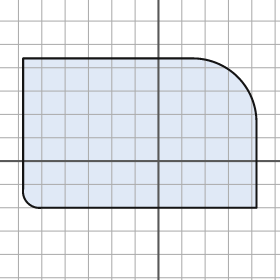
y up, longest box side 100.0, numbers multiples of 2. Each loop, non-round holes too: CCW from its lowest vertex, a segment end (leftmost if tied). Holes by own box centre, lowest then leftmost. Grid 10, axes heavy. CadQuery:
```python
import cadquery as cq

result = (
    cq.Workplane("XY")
    .moveTo(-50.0, -20.0)
    .lineTo(42.0, -20.0)
    .lineTo(42.0, 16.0)
    .threePointArc((34.0, 36.0), (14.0, 44.0))
    .lineTo(-58.0, 44.0)
    .lineTo(-58.0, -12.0)
    .threePointArc((-56.0, -18.0), (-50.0, -20.0))
    .close()
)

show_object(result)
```